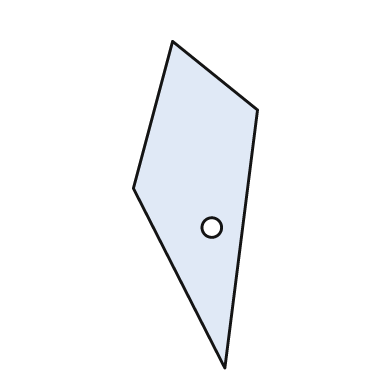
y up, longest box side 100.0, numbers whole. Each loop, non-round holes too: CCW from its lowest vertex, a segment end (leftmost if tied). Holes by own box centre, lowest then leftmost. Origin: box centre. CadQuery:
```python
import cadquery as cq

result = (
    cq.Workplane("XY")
    .moveTo(9.0, -50.0)
    .lineTo(19.0, 29.0)
    .lineTo(-7.0, 50.0)
    .lineTo(-19.0, 5.0)
    .close()
    .moveTo(5.0, -7.0)
    .circle(3.0)
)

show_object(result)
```